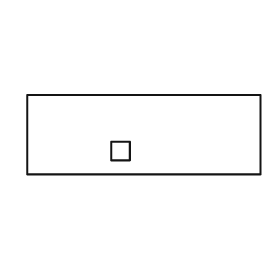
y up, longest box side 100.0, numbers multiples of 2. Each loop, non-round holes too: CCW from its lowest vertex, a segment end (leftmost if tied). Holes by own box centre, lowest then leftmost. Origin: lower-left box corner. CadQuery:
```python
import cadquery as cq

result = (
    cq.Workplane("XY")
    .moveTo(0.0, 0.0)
    .lineTo(100.0, 0.0)
    .lineTo(100.0, 34.0)
    .lineTo(0.0, 34.0)
    .close()
    .moveTo(36.0, 6.0)
    .lineTo(44.0, 6.0)
    .lineTo(44.0, 14.0)
    .lineTo(36.0, 14.0)
    .close()
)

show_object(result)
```